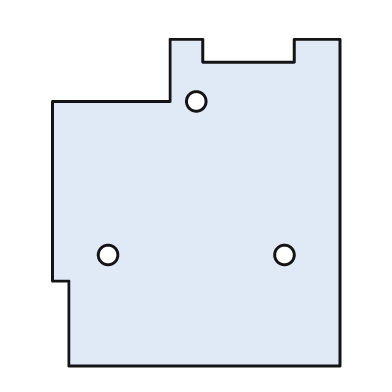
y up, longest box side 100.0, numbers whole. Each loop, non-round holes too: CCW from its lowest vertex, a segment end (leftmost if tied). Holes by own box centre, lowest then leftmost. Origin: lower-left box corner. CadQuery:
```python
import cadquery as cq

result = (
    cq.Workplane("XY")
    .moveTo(5.0, 0.0)
    .lineTo(88.0, 0.0)
    .lineTo(88.0, 100.0)
    .lineTo(74.0, 100.0)
    .lineTo(74.0, 93.0)
    .lineTo(46.0, 93.0)
    .lineTo(46.0, 100.0)
    .lineTo(36.0, 100.0)
    .lineTo(36.0, 81.0)
    .lineTo(0.0, 81.0)
    .lineTo(0.0, 26.0)
    .lineTo(5.0, 26.0)
    .close()
    .moveTo(17.0, 34.0)
    .circle(3.0)
    .moveTo(71.0, 34.0)
    .circle(3.0)
    .moveTo(44.0, 81.0)
    .circle(3.0)
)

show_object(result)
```